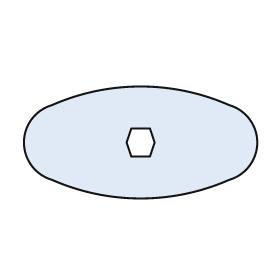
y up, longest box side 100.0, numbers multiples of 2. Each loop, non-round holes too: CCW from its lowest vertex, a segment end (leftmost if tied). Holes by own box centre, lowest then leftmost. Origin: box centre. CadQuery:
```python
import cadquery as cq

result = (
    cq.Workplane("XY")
    .moveTo(-38.0, -16.0)
    .threePointArc((0.0, -24.0), (38.0, -16.0))
    .threePointArc((50.0, 0.0), (38.0, 16.0))
    .threePointArc((0.0, 24.0), (-38.0, 16.0))
    .threePointArc((-50.0, 0.0), (-38.0, -16.0))
    .close()
    .moveTo(-4.0, -6.0)
    .lineTo(4.0, -6.0)
    .lineTo(6.0, 0.0)
    .lineTo(4.0, 6.0)
    .lineTo(-4.0, 6.0)
    .lineTo(-6.0, 0.0)
    .close()
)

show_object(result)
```